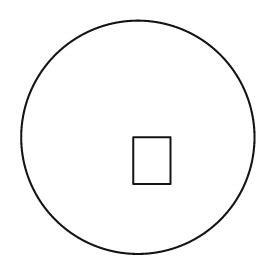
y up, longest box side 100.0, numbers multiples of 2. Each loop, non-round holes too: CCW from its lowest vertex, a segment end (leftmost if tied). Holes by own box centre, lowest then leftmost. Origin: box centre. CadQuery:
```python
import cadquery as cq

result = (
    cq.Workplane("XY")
    .moveTo(0.0, 0.0)
    .circle(50.0)
    .moveTo(-2.0, -20.0)
    .lineTo(14.0, -20.0)
    .lineTo(14.0, 0.0)
    .lineTo(-2.0, 0.0)
    .close()
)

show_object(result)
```